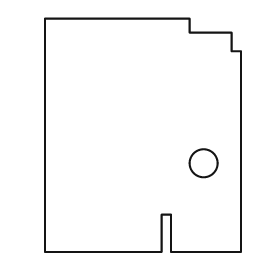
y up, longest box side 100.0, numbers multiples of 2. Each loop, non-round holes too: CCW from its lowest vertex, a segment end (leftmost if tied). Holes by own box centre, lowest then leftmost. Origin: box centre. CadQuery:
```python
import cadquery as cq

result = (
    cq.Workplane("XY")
    .moveTo(-42.0, -50.0)
    .lineTo(8.0, -50.0)
    .lineTo(8.0, -34.0)
    .lineTo(12.0, -34.0)
    .lineTo(12.0, -50.0)
    .lineTo(42.0, -50.0)
    .lineTo(42.0, 36.0)
    .lineTo(38.0, 36.0)
    .lineTo(38.0, 44.0)
    .lineTo(20.0, 44.0)
    .lineTo(20.0, 50.0)
    .lineTo(-42.0, 50.0)
    .close()
    .moveTo(26.0, -12.0)
    .circle(6.0)
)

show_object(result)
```